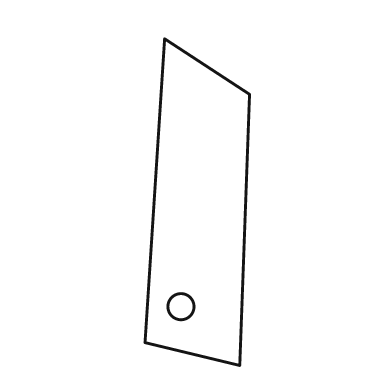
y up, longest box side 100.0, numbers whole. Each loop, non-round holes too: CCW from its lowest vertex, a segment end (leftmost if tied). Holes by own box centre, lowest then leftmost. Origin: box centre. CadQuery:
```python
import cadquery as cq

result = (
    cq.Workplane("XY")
    .moveTo(13.0, -50.0)
    .lineTo(16.0, 33.0)
    .lineTo(-10.0, 50.0)
    .lineTo(-16.0, -43.0)
    .close()
    .moveTo(-5.0, -32.0)
    .circle(4.0)
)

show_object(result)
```